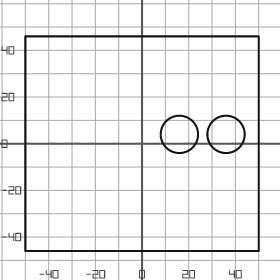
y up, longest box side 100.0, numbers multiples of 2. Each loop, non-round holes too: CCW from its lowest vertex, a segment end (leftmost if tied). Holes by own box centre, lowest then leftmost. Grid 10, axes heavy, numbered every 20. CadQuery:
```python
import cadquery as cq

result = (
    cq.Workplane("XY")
    .moveTo(-50.0, -46.0)
    .lineTo(50.0, -46.0)
    .lineTo(50.0, 46.0)
    .lineTo(-50.0, 46.0)
    .close()
    .moveTo(16.0, 4.0)
    .circle(8.0)
    .moveTo(36.0, 4.0)
    .circle(8.0)
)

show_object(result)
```